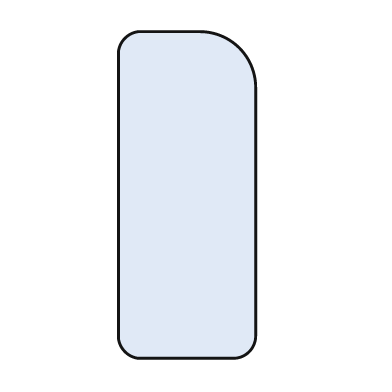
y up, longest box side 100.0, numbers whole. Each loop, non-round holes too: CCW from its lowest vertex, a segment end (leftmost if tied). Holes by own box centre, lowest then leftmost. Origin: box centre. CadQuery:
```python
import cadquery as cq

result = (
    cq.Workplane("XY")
    .moveTo(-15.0, -50.0)
    .lineTo(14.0, -50.0)
    .threePointArc((19.0, -48.0), (21.0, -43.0))
    .lineTo(21.0, 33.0)
    .threePointArc((16.0, 45.0), (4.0, 50.0))
    .lineTo(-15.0, 50.0)
    .threePointArc((-19.0, 48.0), (-21.0, 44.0))
    .lineTo(-21.0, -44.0)
    .threePointArc((-19.0, -48.0), (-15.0, -50.0))
    .close()
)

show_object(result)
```